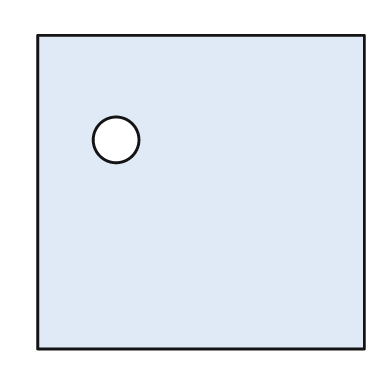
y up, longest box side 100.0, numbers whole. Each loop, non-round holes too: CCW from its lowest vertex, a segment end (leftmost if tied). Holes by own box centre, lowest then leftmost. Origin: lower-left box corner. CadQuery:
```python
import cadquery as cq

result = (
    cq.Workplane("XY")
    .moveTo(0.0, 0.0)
    .lineTo(100.0, 0.0)
    .lineTo(100.0, 96.0)
    .lineTo(0.0, 96.0)
    .close()
    .moveTo(24.0, 64.0)
    .circle(7.0)
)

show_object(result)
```